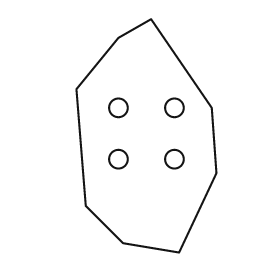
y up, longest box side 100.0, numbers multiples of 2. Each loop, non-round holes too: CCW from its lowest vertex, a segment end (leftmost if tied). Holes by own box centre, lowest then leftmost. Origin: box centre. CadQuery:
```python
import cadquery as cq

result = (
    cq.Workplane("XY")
    .moveTo(14.0, -50.0)
    .lineTo(30.0, -16.0)
    .lineTo(28.0, 12.0)
    .lineTo(2.0, 50.0)
    .lineTo(-12.0, 42.0)
    .lineTo(-30.0, 20.0)
    .lineTo(-26.0, -30.0)
    .lineTo(-10.0, -46.0)
    .close()
    .moveTo(-12.0, -10.0)
    .circle(4.0)
    .moveTo(12.0, -10.0)
    .circle(4.0)
    .moveTo(-12.0, 12.0)
    .circle(4.0)
    .moveTo(12.0, 12.0)
    .circle(4.0)
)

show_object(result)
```